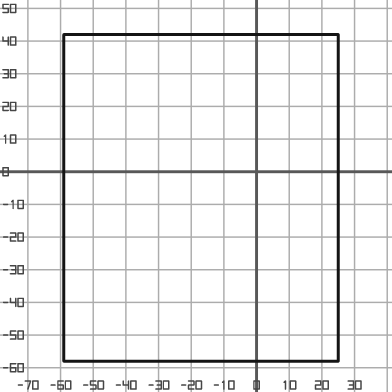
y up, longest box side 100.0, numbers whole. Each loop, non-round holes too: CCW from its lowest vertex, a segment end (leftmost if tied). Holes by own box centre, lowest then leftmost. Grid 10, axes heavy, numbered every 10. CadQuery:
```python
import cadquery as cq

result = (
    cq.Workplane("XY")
    .moveTo(-59.0, -58.0)
    .lineTo(25.0, -58.0)
    .lineTo(25.0, 42.0)
    .lineTo(-59.0, 42.0)
    .close()
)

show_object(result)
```